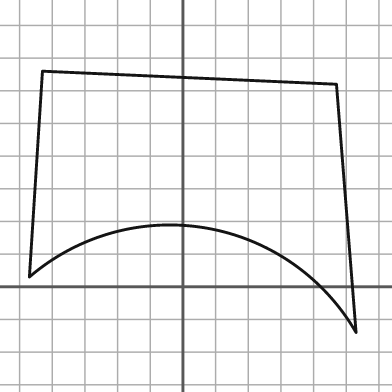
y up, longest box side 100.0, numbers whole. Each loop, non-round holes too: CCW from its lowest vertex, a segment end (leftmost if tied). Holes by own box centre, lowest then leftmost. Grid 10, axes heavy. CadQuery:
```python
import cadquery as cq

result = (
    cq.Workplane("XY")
    .moveTo(53.0, -14.0)
    .lineTo(47.0, 62.0)
    .lineTo(-43.0, 66.0)
    .lineTo(-47.0, 3.0)
    .threePointArc((7.0, 18.0), (53.0, -14.0))
    .close()
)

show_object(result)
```